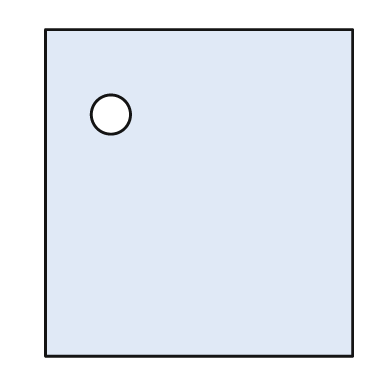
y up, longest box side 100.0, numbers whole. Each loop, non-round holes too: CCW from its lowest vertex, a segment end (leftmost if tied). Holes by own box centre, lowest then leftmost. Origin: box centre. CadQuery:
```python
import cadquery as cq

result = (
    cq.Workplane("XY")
    .moveTo(-47.0, -50.0)
    .lineTo(47.0, -50.0)
    .lineTo(47.0, 50.0)
    .lineTo(-47.0, 50.0)
    .close()
    .moveTo(-27.0, 24.0)
    .circle(6.0)
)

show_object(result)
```